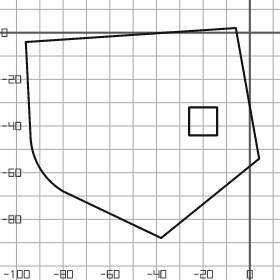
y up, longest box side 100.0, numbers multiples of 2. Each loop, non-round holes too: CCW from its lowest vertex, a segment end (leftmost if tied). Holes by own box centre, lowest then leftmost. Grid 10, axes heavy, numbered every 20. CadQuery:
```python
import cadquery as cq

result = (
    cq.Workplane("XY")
    .moveTo(-38.0, -88.0)
    .lineTo(4.0, -54.0)
    .lineTo(-6.0, 2.0)
    .lineTo(-96.0, -4.0)
    .lineTo(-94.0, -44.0)
    .threePointArc((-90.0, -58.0), (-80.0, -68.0))
    .close()
    .moveTo(-26.0, -44.0)
    .lineTo(-14.0, -44.0)
    .lineTo(-14.0, -32.0)
    .lineTo(-26.0, -32.0)
    .close()
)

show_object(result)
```